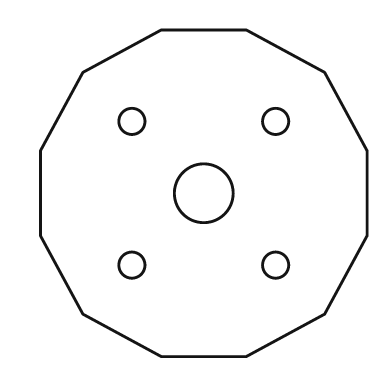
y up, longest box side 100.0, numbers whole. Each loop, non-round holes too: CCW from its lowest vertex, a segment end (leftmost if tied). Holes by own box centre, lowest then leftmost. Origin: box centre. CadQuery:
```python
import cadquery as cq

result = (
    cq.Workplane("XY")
    .moveTo(-13.0, -50.0)
    .lineTo(13.0, -50.0)
    .lineTo(37.0, -37.0)
    .lineTo(50.0, -13.0)
    .lineTo(50.0, 13.0)
    .lineTo(37.0, 37.0)
    .lineTo(13.0, 50.0)
    .lineTo(-13.0, 50.0)
    .lineTo(-37.0, 37.0)
    .lineTo(-50.0, 13.0)
    .lineTo(-50.0, -13.0)
    .lineTo(-37.0, -37.0)
    .close()
    .moveTo(-22.0, -22.0)
    .circle(4.0)
    .moveTo(22.0, -22.0)
    .circle(4.0)
    .moveTo(0.0, 0.0)
    .circle(9.0)
    .moveTo(-22.0, 22.0)
    .circle(4.0)
    .moveTo(22.0, 22.0)
    .circle(4.0)
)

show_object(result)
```